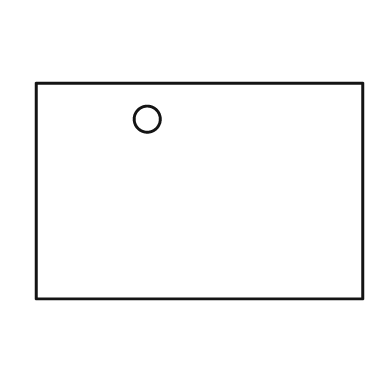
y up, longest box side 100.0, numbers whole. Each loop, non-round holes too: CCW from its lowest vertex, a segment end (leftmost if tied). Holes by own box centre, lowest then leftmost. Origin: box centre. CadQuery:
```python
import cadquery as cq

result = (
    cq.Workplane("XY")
    .moveTo(-50.0, -33.0)
    .lineTo(50.0, -33.0)
    .lineTo(50.0, 33.0)
    .lineTo(-50.0, 33.0)
    .close()
    .moveTo(-16.0, 22.0)
    .circle(4.0)
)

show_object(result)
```